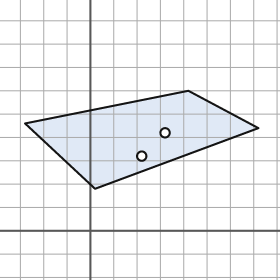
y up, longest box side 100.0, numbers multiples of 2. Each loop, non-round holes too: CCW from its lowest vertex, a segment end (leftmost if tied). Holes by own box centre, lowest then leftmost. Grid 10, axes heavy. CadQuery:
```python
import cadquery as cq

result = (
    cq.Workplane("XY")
    .moveTo(2.0, 18.0)
    .lineTo(72.0, 44.0)
    .lineTo(42.0, 60.0)
    .lineTo(-28.0, 46.0)
    .close()
    .moveTo(22.0, 32.0)
    .circle(2.0)
    .moveTo(32.0, 42.0)
    .circle(2.0)
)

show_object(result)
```